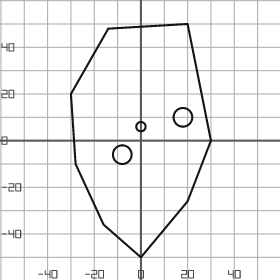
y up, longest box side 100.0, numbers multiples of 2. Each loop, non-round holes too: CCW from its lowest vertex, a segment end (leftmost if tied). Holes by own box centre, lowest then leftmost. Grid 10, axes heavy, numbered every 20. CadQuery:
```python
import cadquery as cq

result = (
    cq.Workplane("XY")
    .moveTo(0.0, -50.0)
    .lineTo(20.0, -26.0)
    .lineTo(30.0, 0.0)
    .lineTo(20.0, 50.0)
    .lineTo(-14.0, 48.0)
    .lineTo(-30.0, 20.0)
    .lineTo(-28.0, -10.0)
    .lineTo(-16.0, -36.0)
    .close()
    .moveTo(-8.0, -6.0)
    .circle(4.0)
    .moveTo(0.0, 6.0)
    .circle(2.0)
    .moveTo(18.0, 10.0)
    .circle(4.0)
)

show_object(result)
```